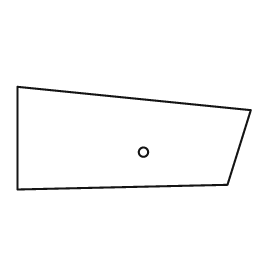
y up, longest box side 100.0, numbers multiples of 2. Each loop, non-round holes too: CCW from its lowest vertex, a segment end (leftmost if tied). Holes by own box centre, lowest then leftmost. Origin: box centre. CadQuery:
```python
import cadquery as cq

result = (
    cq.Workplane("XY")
    .moveTo(-50.0, -22.0)
    .lineTo(40.0, -20.0)
    .lineTo(50.0, 12.0)
    .lineTo(-50.0, 22.0)
    .close()
    .moveTo(4.0, -6.0)
    .circle(2.0)
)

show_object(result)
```